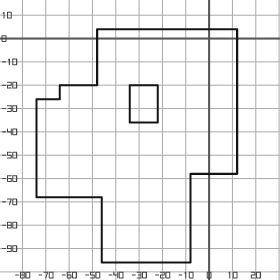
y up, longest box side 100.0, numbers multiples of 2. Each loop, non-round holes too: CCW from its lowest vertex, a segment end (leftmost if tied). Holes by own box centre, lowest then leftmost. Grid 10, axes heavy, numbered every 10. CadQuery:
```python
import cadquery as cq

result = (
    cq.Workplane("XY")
    .moveTo(-46.0, -96.0)
    .lineTo(-8.0, -96.0)
    .lineTo(-8.0, -58.0)
    .lineTo(12.0, -58.0)
    .lineTo(12.0, 4.0)
    .lineTo(-48.0, 4.0)
    .lineTo(-48.0, -20.0)
    .lineTo(-64.0, -20.0)
    .lineTo(-64.0, -26.0)
    .lineTo(-74.0, -26.0)
    .lineTo(-74.0, -68.0)
    .lineTo(-46.0, -68.0)
    .close()
    .moveTo(-34.0, -36.0)
    .lineTo(-22.0, -36.0)
    .lineTo(-22.0, -20.0)
    .lineTo(-34.0, -20.0)
    .close()
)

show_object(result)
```